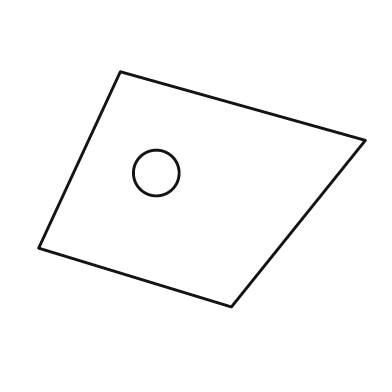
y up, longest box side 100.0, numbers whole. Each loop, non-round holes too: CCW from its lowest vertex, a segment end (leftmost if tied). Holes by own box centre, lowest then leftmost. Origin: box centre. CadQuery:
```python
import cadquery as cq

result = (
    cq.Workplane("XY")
    .moveTo(9.0, -36.0)
    .lineTo(50.0, 15.0)
    .lineTo(-25.0, 36.0)
    .lineTo(-50.0, -18.0)
    .close()
    .moveTo(-14.0, 5.0)
    .circle(7.0)
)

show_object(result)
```